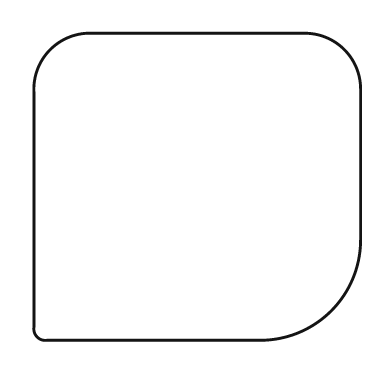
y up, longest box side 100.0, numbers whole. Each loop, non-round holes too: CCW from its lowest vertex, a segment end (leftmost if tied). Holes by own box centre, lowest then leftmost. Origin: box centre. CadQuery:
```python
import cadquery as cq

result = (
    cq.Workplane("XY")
    .moveTo(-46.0, -47.0)
    .lineTo(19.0, -47.0)
    .threePointArc((41.0, -38.0), (50.0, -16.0))
    .lineTo(50.0, 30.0)
    .threePointArc((45.0, 42.0), (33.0, 47.0))
    .lineTo(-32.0, 47.0)
    .threePointArc((-45.0, 42.0), (-50.0, 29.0))
    .lineTo(-50.0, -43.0)
    .threePointArc((-49.0, -46.0), (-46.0, -47.0))
    .close()
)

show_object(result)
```